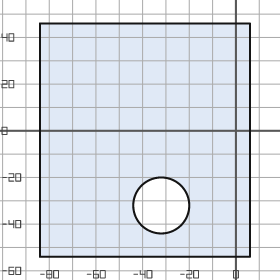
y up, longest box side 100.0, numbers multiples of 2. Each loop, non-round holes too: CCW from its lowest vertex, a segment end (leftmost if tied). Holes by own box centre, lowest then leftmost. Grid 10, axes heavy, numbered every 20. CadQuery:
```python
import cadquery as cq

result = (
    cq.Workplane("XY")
    .moveTo(-84.0, -54.0)
    .lineTo(6.0, -54.0)
    .lineTo(6.0, 46.0)
    .lineTo(-84.0, 46.0)
    .close()
    .moveTo(-32.0, -32.0)
    .circle(12.0)
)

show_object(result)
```